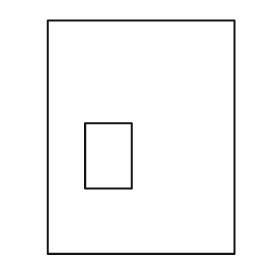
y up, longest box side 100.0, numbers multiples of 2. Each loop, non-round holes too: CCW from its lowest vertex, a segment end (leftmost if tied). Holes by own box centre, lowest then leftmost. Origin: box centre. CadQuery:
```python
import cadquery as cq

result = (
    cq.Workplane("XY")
    .moveTo(-40.0, -50.0)
    .lineTo(40.0, -50.0)
    .lineTo(40.0, 50.0)
    .lineTo(-40.0, 50.0)
    .close()
    .moveTo(-24.0, -22.0)
    .lineTo(-4.0, -22.0)
    .lineTo(-4.0, 6.0)
    .lineTo(-24.0, 6.0)
    .close()
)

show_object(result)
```